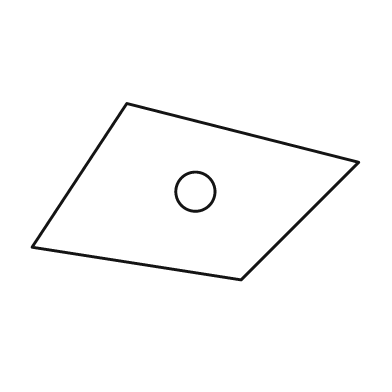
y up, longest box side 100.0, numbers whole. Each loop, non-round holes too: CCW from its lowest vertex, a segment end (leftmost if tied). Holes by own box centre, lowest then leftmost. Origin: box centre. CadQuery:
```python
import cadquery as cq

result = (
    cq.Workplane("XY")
    .moveTo(14.0, -27.0)
    .lineTo(50.0, 9.0)
    .lineTo(-21.0, 27.0)
    .lineTo(-50.0, -17.0)
    .close()
    .moveTo(0.0, 0.0)
    .circle(6.0)
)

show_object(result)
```